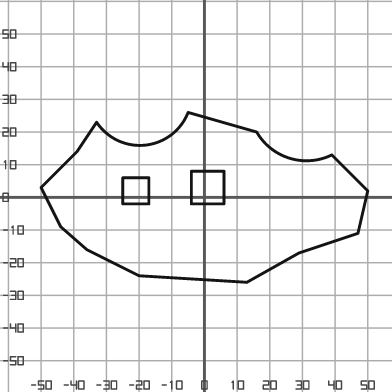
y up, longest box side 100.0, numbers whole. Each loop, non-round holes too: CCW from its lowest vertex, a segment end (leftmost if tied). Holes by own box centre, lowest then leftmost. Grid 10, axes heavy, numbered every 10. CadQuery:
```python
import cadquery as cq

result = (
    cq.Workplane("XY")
    .moveTo(13.0, -26.0)
    .lineTo(29.0, -17.0)
    .lineTo(47.0, -11.0)
    .lineTo(50.0, 2.0)
    .lineTo(39.0, 13.0)
    .threePointArc((26.0, 12.0), (16.0, 20.0))
    .lineTo(-5.0, 26.0)
    .threePointArc((-18.0, 16.0), (-33.0, 23.0))
    .lineTo(-39.0, 14.0)
    .lineTo(-50.0, 3.0)
    .lineTo(-44.0, -9.0)
    .lineTo(-36.0, -16.0)
    .lineTo(-20.0, -24.0)
    .close()
    .moveTo(-25.0, -2.0)
    .lineTo(-17.0, -2.0)
    .lineTo(-17.0, 6.0)
    .lineTo(-25.0, 6.0)
    .close()
    .moveTo(-4.0, -2.0)
    .lineTo(6.0, -2.0)
    .lineTo(6.0, 8.0)
    .lineTo(-4.0, 8.0)
    .close()
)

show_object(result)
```